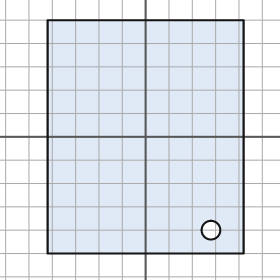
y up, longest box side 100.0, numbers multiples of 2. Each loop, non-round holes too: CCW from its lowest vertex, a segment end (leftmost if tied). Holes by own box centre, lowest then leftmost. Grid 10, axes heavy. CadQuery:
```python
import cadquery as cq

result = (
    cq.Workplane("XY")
    .moveTo(-42.0, -50.0)
    .lineTo(42.0, -50.0)
    .lineTo(42.0, 50.0)
    .lineTo(-42.0, 50.0)
    .close()
    .moveTo(28.0, -40.0)
    .circle(4.0)
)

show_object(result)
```